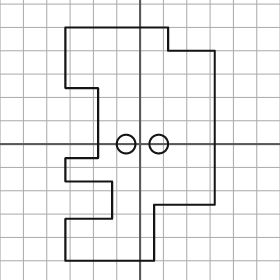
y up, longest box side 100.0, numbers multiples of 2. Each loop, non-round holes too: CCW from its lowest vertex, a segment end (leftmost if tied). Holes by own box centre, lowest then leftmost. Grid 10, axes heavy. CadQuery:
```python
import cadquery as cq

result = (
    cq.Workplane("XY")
    .moveTo(-32.0, -50.0)
    .lineTo(6.0, -50.0)
    .lineTo(6.0, -26.0)
    .lineTo(32.0, -26.0)
    .lineTo(32.0, 40.0)
    .lineTo(12.0, 40.0)
    .lineTo(12.0, 50.0)
    .lineTo(-32.0, 50.0)
    .lineTo(-32.0, 24.0)
    .lineTo(-18.0, 24.0)
    .lineTo(-18.0, -6.0)
    .lineTo(-32.0, -6.0)
    .lineTo(-32.0, -16.0)
    .lineTo(-12.0, -16.0)
    .lineTo(-12.0, -32.0)
    .lineTo(-32.0, -32.0)
    .close()
    .moveTo(-6.0, 0.0)
    .circle(4.0)
    .moveTo(8.0, 0.0)
    .circle(4.0)
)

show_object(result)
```